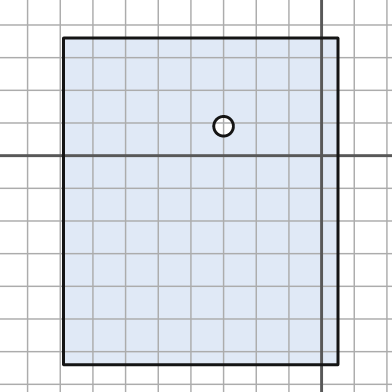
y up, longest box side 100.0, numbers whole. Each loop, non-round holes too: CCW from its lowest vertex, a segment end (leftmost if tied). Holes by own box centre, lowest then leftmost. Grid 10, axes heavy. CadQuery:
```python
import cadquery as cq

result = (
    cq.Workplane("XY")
    .moveTo(-79.0, -64.0)
    .lineTo(5.0, -64.0)
    .lineTo(5.0, 36.0)
    .lineTo(-79.0, 36.0)
    .close()
    .moveTo(-30.0, 9.0)
    .circle(3.0)
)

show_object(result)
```